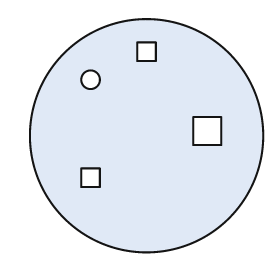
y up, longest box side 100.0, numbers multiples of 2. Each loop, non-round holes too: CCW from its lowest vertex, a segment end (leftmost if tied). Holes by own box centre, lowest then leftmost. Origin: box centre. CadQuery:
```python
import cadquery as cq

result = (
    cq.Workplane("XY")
    .moveTo(0.0, 0.0)
    .circle(50.0)
    .moveTo(-28.0, -22.0)
    .lineTo(-20.0, -22.0)
    .lineTo(-20.0, -14.0)
    .lineTo(-28.0, -14.0)
    .close()
    .moveTo(20.0, -4.0)
    .lineTo(32.0, -4.0)
    .lineTo(32.0, 8.0)
    .lineTo(20.0, 8.0)
    .close()
    .moveTo(-24.0, 24.0)
    .circle(4.0)
    .moveTo(-4.0, 32.0)
    .lineTo(4.0, 32.0)
    .lineTo(4.0, 40.0)
    .lineTo(-4.0, 40.0)
    .close()
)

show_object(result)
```